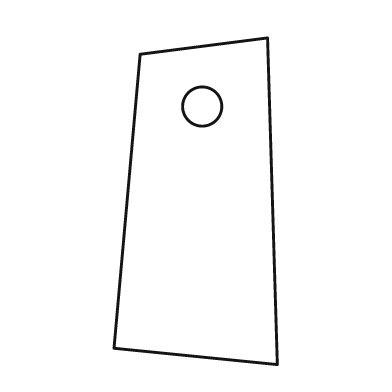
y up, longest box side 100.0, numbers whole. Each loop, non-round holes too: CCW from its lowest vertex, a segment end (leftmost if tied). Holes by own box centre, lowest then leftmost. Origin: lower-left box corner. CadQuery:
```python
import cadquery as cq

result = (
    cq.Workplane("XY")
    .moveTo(50.0, 0.0)
    .lineTo(47.0, 100.0)
    .lineTo(8.0, 95.0)
    .lineTo(0.0, 5.0)
    .close()
    .moveTo(27.0, 79.0)
    .circle(6.0)
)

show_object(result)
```